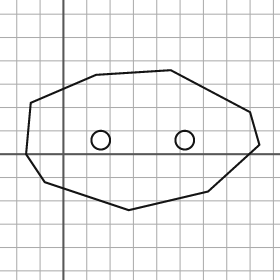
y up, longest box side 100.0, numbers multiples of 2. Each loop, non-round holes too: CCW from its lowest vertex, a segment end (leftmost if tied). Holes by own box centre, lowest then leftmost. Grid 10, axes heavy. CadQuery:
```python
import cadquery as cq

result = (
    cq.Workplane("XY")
    .moveTo(28.0, -24.0)
    .lineTo(62.0, -16.0)
    .lineTo(84.0, 4.0)
    .lineTo(80.0, 18.0)
    .lineTo(46.0, 36.0)
    .lineTo(14.0, 34.0)
    .lineTo(-14.0, 22.0)
    .lineTo(-16.0, 0.0)
    .lineTo(-8.0, -12.0)
    .close()
    .moveTo(16.0, 6.0)
    .circle(4.0)
    .moveTo(52.0, 6.0)
    .circle(4.0)
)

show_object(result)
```